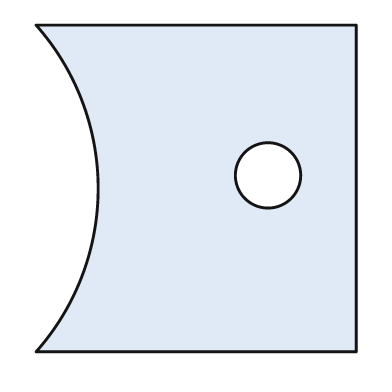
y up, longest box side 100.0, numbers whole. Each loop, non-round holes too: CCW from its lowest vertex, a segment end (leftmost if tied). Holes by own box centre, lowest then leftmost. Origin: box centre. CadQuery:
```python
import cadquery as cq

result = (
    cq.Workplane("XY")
    .moveTo(-49.0, -50.0)
    .lineTo(49.0, -50.0)
    .lineTo(49.0, 50.0)
    .lineTo(-49.0, 50.0)
    .threePointArc((-30.0, 0.0), (-49.0, -50.0))
    .close()
    .moveTo(22.0, 4.0)
    .circle(10.0)
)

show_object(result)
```